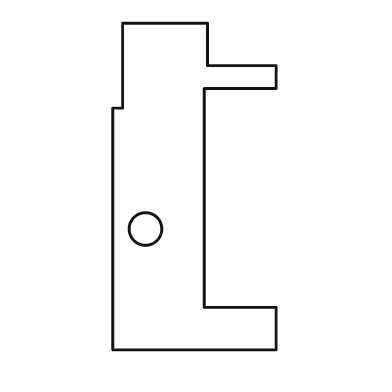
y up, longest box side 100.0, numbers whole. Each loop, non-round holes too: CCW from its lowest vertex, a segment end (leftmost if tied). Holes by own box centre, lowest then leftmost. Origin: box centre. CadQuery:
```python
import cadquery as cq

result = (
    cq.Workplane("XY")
    .moveTo(-25.0, -50.0)
    .lineTo(25.0, -50.0)
    .lineTo(25.0, -37.0)
    .lineTo(3.0, -37.0)
    .lineTo(3.0, 30.0)
    .lineTo(25.0, 30.0)
    .lineTo(25.0, 37.0)
    .lineTo(4.0, 37.0)
    .lineTo(4.0, 50.0)
    .lineTo(-22.0, 50.0)
    .lineTo(-22.0, 24.0)
    .lineTo(-25.0, 24.0)
    .close()
    .moveTo(-15.0, -13.0)
    .circle(5.0)
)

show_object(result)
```